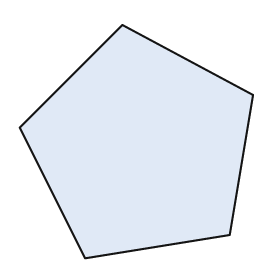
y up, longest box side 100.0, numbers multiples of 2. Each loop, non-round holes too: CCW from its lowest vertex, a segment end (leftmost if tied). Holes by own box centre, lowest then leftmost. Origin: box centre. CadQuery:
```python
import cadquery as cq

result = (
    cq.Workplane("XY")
    .moveTo(-22.0, -50.0)
    .lineTo(40.0, -40.0)
    .lineTo(50.0, 20.0)
    .lineTo(-6.0, 50.0)
    .lineTo(-50.0, 6.0)
    .close()
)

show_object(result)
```